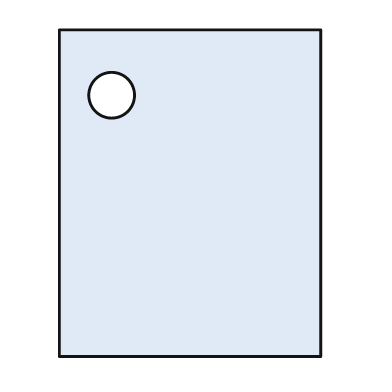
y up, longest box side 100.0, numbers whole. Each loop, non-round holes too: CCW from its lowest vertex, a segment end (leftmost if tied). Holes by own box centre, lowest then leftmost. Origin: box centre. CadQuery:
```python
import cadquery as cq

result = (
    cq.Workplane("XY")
    .moveTo(-40.0, -50.0)
    .lineTo(40.0, -50.0)
    .lineTo(40.0, 50.0)
    .lineTo(-40.0, 50.0)
    .close()
    .moveTo(-24.0, 30.0)
    .circle(7.0)
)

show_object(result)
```